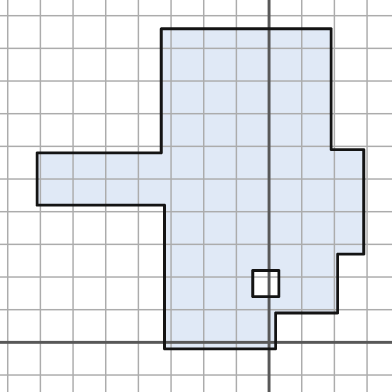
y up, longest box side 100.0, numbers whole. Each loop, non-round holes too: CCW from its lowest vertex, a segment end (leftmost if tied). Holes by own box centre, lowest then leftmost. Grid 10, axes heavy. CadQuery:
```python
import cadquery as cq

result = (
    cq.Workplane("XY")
    .moveTo(-32.0, -2.0)
    .lineTo(2.0, -2.0)
    .lineTo(2.0, 9.0)
    .lineTo(21.0, 9.0)
    .lineTo(21.0, 27.0)
    .lineTo(29.0, 27.0)
    .lineTo(29.0, 59.0)
    .lineTo(19.0, 59.0)
    .lineTo(19.0, 96.0)
    .lineTo(-33.0, 96.0)
    .lineTo(-33.0, 58.0)
    .lineTo(-71.0, 58.0)
    .lineTo(-71.0, 42.0)
    .lineTo(-32.0, 42.0)
    .close()
    .moveTo(-5.0, 14.0)
    .lineTo(3.0, 14.0)
    .lineTo(3.0, 22.0)
    .lineTo(-5.0, 22.0)
    .close()
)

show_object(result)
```